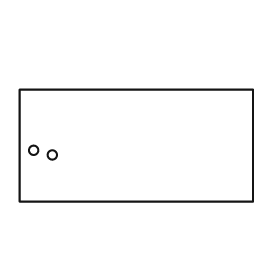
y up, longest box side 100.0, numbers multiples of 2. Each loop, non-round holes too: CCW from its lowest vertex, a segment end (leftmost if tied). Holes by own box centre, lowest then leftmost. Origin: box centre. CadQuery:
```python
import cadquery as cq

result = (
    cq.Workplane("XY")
    .moveTo(-50.0, -24.0)
    .lineTo(50.0, -24.0)
    .lineTo(50.0, 24.0)
    .lineTo(-50.0, 24.0)
    .close()
    .moveTo(-36.0, -4.0)
    .circle(2.0)
    .moveTo(-44.0, -2.0)
    .circle(2.0)
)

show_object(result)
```